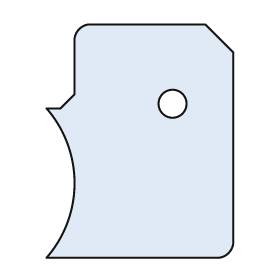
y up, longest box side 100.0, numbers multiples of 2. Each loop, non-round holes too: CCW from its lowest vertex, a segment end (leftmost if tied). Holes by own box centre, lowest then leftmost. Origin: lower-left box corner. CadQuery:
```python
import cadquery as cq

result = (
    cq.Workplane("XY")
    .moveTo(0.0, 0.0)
    .lineTo(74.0, 0.0)
    .threePointArc((78.0, 2.0), (80.0, 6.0))
    .lineTo(80.0, 88.0)
    .lineTo(68.0, 100.0)
    .lineTo(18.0, 100.0)
    .threePointArc((14.0, 98.0), (12.0, 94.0))
    .lineTo(12.0, 70.0)
    .lineTo(6.0, 64.0)
    .lineTo(0.0, 64.0)
    .threePointArc((12.0, 32.0), (0.0, 0.0))
    .close()
    .moveTo(54.0, 66.0)
    .circle(6.0)
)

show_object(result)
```